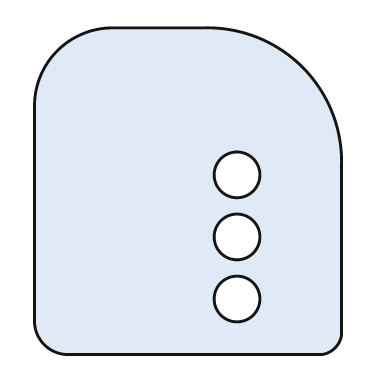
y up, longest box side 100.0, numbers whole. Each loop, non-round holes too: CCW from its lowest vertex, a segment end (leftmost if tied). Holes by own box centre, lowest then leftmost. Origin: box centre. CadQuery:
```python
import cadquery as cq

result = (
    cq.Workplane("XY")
    .moveTo(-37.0, -50.0)
    .lineTo(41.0, -50.0)
    .threePointArc((45.0, -48.0), (47.0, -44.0))
    .lineTo(47.0, 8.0)
    .threePointArc((35.0, 38.0), (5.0, 50.0))
    .lineTo(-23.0, 50.0)
    .threePointArc((-40.0, 43.0), (-47.0, 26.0))
    .lineTo(-47.0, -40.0)
    .threePointArc((-44.0, -47.0), (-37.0, -50.0))
    .close()
    .moveTo(15.0, -33.0)
    .circle(7.0)
    .moveTo(15.0, -14.0)
    .circle(7.0)
    .moveTo(15.0, 5.0)
    .circle(7.0)
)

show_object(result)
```